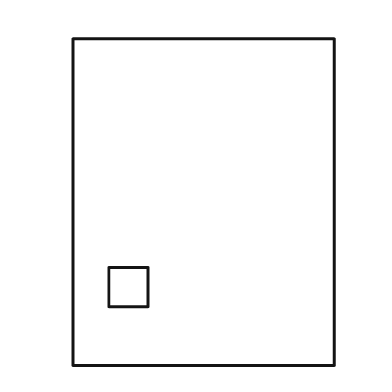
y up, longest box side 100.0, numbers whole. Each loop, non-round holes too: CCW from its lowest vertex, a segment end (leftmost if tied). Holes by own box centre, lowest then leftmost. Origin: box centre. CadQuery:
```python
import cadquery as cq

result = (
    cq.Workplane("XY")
    .moveTo(-40.0, -50.0)
    .lineTo(40.0, -50.0)
    .lineTo(40.0, 50.0)
    .lineTo(-40.0, 50.0)
    .close()
    .moveTo(-29.0, -32.0)
    .lineTo(-17.0, -32.0)
    .lineTo(-17.0, -20.0)
    .lineTo(-29.0, -20.0)
    .close()
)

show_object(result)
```